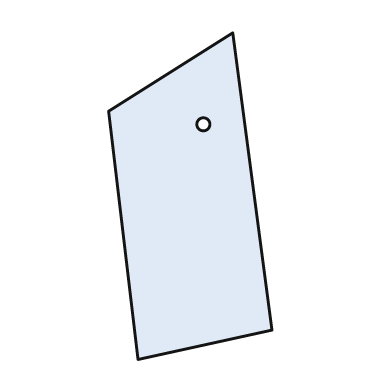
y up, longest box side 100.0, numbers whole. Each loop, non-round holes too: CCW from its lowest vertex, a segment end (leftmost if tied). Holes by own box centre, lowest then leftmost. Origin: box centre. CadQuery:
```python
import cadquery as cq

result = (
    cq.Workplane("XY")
    .moveTo(-16.0, -50.0)
    .lineTo(25.0, -41.0)
    .lineTo(13.0, 50.0)
    .lineTo(-25.0, 26.0)
    .close()
    .moveTo(4.0, 22.0)
    .circle(2.0)
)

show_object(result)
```